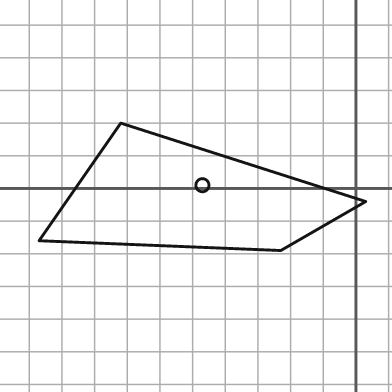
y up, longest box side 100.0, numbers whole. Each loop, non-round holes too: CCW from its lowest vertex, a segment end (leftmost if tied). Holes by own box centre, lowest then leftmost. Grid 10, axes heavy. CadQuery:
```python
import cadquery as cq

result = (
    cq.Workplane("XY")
    .moveTo(-23.0, -19.0)
    .lineTo(3.0, -4.0)
    .lineTo(-72.0, 20.0)
    .lineTo(-97.0, -16.0)
    .close()
    .moveTo(-47.0, 1.0)
    .circle(2.0)
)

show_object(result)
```